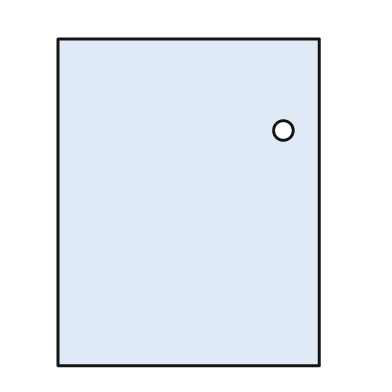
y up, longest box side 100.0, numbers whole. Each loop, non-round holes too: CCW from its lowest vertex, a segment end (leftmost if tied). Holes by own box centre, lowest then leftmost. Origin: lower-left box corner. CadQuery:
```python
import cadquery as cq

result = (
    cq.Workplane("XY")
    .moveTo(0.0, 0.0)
    .lineTo(80.0, 0.0)
    .lineTo(80.0, 100.0)
    .lineTo(0.0, 100.0)
    .close()
    .moveTo(69.0, 72.0)
    .circle(3.0)
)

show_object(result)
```